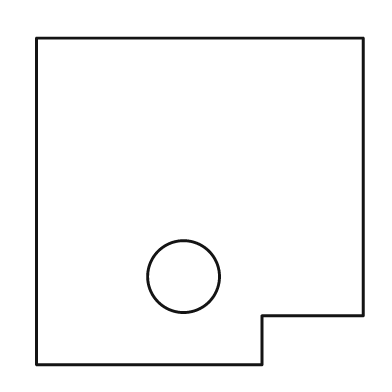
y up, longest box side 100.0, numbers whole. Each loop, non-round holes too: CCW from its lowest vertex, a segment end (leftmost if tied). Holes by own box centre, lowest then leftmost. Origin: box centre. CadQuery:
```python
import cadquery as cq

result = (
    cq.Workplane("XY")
    .moveTo(-50.0, -50.0)
    .lineTo(19.0, -50.0)
    .lineTo(19.0, -35.0)
    .lineTo(50.0, -35.0)
    .lineTo(50.0, 50.0)
    .lineTo(-50.0, 50.0)
    .close()
    .moveTo(-5.0, -23.0)
    .circle(11.0)
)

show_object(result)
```